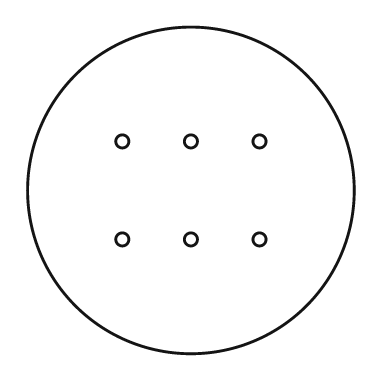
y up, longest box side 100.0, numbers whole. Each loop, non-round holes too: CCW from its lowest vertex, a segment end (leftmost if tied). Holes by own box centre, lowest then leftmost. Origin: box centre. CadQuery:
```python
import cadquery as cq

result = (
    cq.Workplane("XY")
    .moveTo(0.0, 0.0)
    .circle(50.0)
    .moveTo(-21.0, -15.0)
    .circle(2.0)
    .moveTo(0.0, -15.0)
    .circle(2.0)
    .moveTo(21.0, -15.0)
    .circle(2.0)
    .moveTo(-21.0, 15.0)
    .circle(2.0)
    .moveTo(0.0, 15.0)
    .circle(2.0)
    .moveTo(21.0, 15.0)
    .circle(2.0)
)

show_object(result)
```